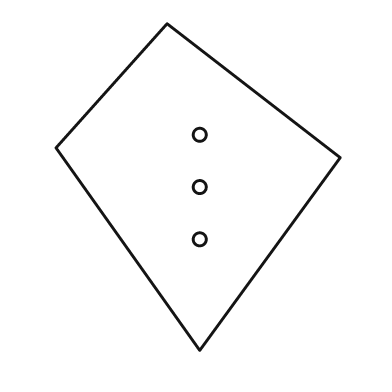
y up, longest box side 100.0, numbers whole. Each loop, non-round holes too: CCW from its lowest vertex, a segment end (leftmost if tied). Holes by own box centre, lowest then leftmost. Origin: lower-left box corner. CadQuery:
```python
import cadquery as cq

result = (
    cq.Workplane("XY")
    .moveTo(44.0, 0.0)
    .lineTo(87.0, 59.0)
    .lineTo(34.0, 100.0)
    .lineTo(0.0, 62.0)
    .close()
    .moveTo(44.0, 34.0)
    .circle(2.0)
    .moveTo(44.0, 50.0)
    .circle(2.0)
    .moveTo(44.0, 66.0)
    .circle(2.0)
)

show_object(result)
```